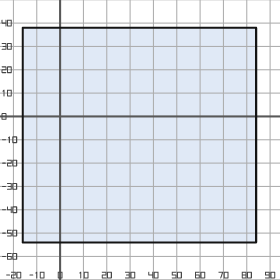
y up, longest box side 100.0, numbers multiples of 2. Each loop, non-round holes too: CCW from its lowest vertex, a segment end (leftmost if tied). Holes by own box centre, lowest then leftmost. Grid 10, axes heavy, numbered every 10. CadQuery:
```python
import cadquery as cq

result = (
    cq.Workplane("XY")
    .moveTo(-16.0, -54.0)
    .lineTo(84.0, -54.0)
    .lineTo(84.0, 38.0)
    .lineTo(-16.0, 38.0)
    .close()
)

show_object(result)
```